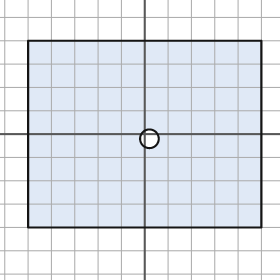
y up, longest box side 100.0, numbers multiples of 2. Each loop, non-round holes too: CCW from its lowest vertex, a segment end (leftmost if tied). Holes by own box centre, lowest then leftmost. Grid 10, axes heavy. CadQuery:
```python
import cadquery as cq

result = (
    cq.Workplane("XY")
    .moveTo(-50.0, -40.0)
    .lineTo(50.0, -40.0)
    .lineTo(50.0, 40.0)
    .lineTo(-50.0, 40.0)
    .close()
    .moveTo(2.0, -2.0)
    .circle(4.0)
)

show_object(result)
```